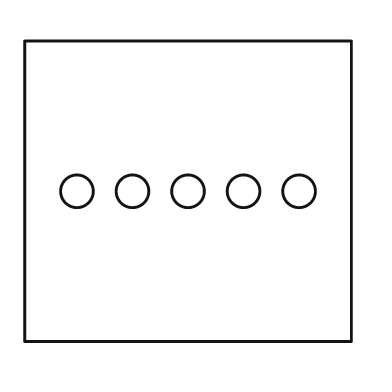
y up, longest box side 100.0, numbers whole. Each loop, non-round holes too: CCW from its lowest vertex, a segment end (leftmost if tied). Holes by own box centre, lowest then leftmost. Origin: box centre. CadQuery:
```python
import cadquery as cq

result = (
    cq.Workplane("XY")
    .moveTo(-50.0, -46.0)
    .lineTo(50.0, -46.0)
    .lineTo(50.0, 46.0)
    .lineTo(-50.0, 46.0)
    .close()
    .moveTo(-34.0, 0.0)
    .circle(5.0)
    .moveTo(-17.0, 0.0)
    .circle(5.0)
    .moveTo(0.0, 0.0)
    .circle(5.0)
    .moveTo(17.0, 0.0)
    .circle(5.0)
    .moveTo(34.0, 0.0)
    .circle(5.0)
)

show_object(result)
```